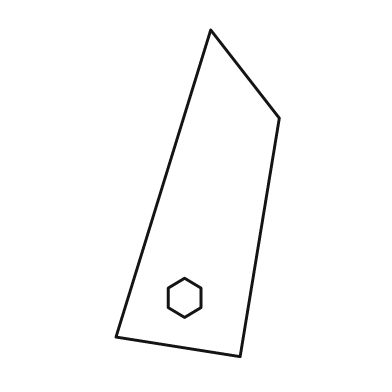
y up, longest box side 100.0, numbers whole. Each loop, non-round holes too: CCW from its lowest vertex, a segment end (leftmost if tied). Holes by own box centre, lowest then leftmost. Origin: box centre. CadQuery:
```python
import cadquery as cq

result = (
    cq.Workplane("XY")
    .moveTo(13.0, -50.0)
    .lineTo(25.0, 23.0)
    .lineTo(4.0, 50.0)
    .lineTo(-25.0, -44.0)
    .close()
    .moveTo(-4.0, -38.0)
    .lineTo(1.0, -35.0)
    .lineTo(1.0, -29.0)
    .lineTo(-4.0, -26.0)
    .lineTo(-9.0, -29.0)
    .lineTo(-9.0, -35.0)
    .close()
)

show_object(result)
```